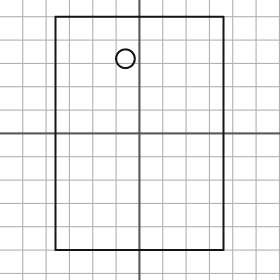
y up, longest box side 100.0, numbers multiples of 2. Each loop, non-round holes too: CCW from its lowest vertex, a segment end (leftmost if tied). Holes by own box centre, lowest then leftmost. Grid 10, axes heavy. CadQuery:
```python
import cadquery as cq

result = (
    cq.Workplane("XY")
    .moveTo(-36.0, -50.0)
    .lineTo(36.0, -50.0)
    .lineTo(36.0, 50.0)
    .lineTo(-36.0, 50.0)
    .close()
    .moveTo(-6.0, 32.0)
    .circle(4.0)
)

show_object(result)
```